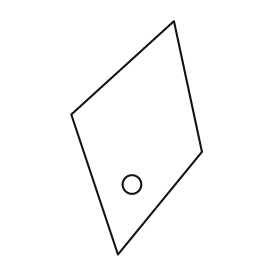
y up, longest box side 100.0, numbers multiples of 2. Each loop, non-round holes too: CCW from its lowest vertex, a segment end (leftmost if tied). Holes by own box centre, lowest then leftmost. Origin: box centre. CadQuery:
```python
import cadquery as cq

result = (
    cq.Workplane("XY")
    .moveTo(-8.0, -50.0)
    .lineTo(28.0, -6.0)
    .lineTo(16.0, 50.0)
    .lineTo(-28.0, 10.0)
    .close()
    .moveTo(-2.0, -20.0)
    .circle(4.0)
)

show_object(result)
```